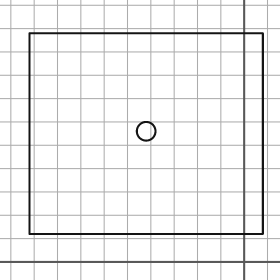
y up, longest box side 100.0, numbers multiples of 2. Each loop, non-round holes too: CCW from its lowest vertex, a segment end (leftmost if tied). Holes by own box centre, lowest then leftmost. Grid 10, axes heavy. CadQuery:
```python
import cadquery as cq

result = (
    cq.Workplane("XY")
    .moveTo(-92.0, 12.0)
    .lineTo(8.0, 12.0)
    .lineTo(8.0, 98.0)
    .lineTo(-92.0, 98.0)
    .close()
    .moveTo(-42.0, 56.0)
    .circle(4.0)
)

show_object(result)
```